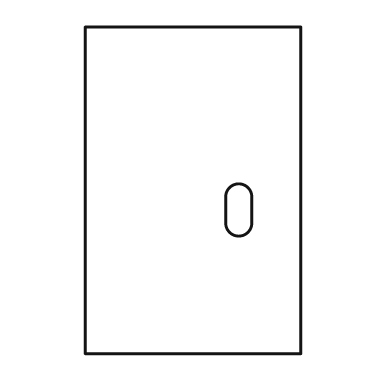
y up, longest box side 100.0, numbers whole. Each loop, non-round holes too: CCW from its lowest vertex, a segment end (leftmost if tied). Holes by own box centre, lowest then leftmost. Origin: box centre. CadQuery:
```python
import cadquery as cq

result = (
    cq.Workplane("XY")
    .moveTo(-33.0, -50.0)
    .lineTo(33.0, -50.0)
    .lineTo(33.0, 50.0)
    .lineTo(-33.0, 50.0)
    .close()
    .moveTo(10.0, -10.0)
    .threePointArc((14.0, -14.0), (18.0, -10.0))
    .lineTo(18.0, -2.0)
    .threePointArc((14.0, 2.0), (10.0, -2.0))
    .close()
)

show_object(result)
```